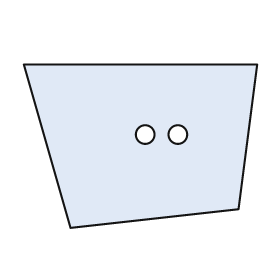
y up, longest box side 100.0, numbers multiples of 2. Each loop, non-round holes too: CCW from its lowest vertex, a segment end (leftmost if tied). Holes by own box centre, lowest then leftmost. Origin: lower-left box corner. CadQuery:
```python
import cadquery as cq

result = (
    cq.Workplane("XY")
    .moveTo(20.0, 0.0)
    .lineTo(92.0, 8.0)
    .lineTo(100.0, 70.0)
    .lineTo(0.0, 70.0)
    .close()
    .moveTo(52.0, 40.0)
    .circle(4.0)
    .moveTo(66.0, 40.0)
    .circle(4.0)
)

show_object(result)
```